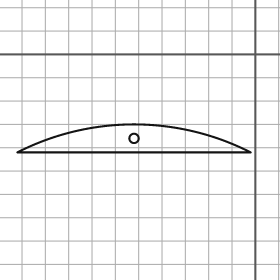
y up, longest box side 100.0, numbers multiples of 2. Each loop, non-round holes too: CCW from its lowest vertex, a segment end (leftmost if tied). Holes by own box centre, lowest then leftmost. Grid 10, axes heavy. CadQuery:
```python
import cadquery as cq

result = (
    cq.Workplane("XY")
    .moveTo(-102.0, -42.0)
    .lineTo(-2.0, -42.0)
    .threePointArc((-52.0, -30.0), (-102.0, -42.0))
    .close()
    .moveTo(-52.0, -36.0)
    .circle(2.0)
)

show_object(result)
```